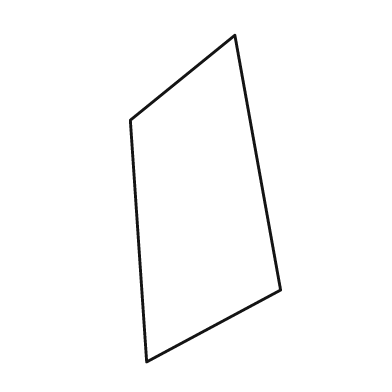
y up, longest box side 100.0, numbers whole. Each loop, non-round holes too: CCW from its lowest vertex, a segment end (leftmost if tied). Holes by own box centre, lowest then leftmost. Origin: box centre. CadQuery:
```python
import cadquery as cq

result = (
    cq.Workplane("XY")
    .moveTo(-18.0, -50.0)
    .lineTo(23.0, -28.0)
    .lineTo(9.0, 50.0)
    .lineTo(-23.0, 24.0)
    .close()
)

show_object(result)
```